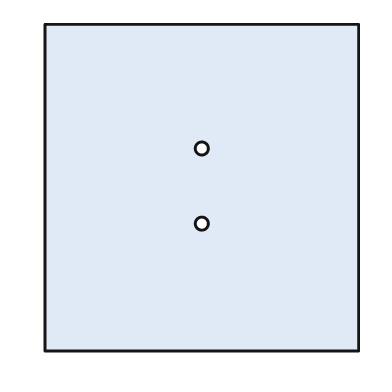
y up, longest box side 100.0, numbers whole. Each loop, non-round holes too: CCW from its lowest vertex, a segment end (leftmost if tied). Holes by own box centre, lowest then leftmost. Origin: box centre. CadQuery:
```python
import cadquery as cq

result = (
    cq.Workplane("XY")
    .moveTo(-48.0, -50.0)
    .lineTo(48.0, -50.0)
    .lineTo(48.0, 50.0)
    .lineTo(-48.0, 50.0)
    .close()
    .moveTo(0.0, -11.0)
    .circle(2.0)
    .moveTo(0.0, 12.0)
    .circle(2.0)
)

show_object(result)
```